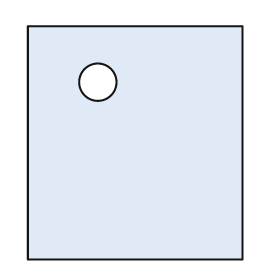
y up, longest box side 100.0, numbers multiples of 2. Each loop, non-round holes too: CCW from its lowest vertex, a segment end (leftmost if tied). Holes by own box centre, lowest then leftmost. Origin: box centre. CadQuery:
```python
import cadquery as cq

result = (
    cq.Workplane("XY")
    .moveTo(-46.0, -50.0)
    .lineTo(46.0, -50.0)
    .lineTo(46.0, 50.0)
    .lineTo(-46.0, 50.0)
    .close()
    .moveTo(-16.0, 26.0)
    .circle(8.0)
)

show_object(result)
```